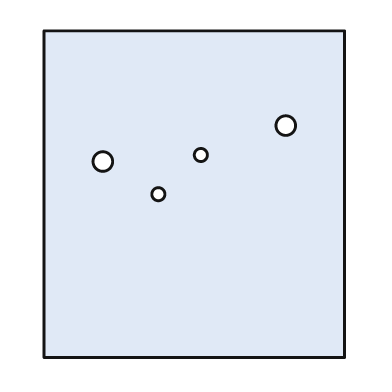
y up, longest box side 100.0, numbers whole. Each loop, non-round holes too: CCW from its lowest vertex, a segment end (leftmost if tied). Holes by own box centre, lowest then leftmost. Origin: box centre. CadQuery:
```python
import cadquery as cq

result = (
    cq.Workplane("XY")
    .moveTo(-46.0, -50.0)
    .lineTo(46.0, -50.0)
    .lineTo(46.0, 50.0)
    .lineTo(-46.0, 50.0)
    .close()
    .moveTo(-11.0, 0.0)
    .circle(2.0)
    .moveTo(-28.0, 10.0)
    .circle(3.0)
    .moveTo(2.0, 12.0)
    .circle(2.0)
    .moveTo(28.0, 21.0)
    .circle(3.0)
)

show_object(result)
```